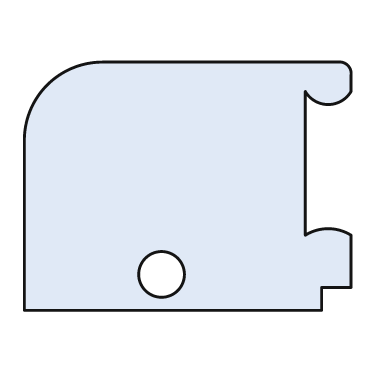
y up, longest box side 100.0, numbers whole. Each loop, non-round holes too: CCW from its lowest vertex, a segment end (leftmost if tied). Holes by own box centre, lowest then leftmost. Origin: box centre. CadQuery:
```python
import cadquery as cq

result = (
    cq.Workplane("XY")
    .moveTo(-50.0, -38.0)
    .lineTo(41.0, -38.0)
    .lineTo(41.0, -31.0)
    .lineTo(50.0, -31.0)
    .lineTo(50.0, -15.0)
    .threePointArc((43.0, -13.0), (36.0, -15.0))
    .lineTo(36.0, 29.0)
    .threePointArc((43.0, 25.0), (50.0, 29.0))
    .lineTo(50.0, 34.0)
    .threePointArc((49.0, 37.0), (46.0, 38.0))
    .lineTo(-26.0, 38.0)
    .threePointArc((-43.0, 31.0), (-50.0, 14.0))
    .close()
    .moveTo(-8.0, -27.0)
    .circle(7.0)
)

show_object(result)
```